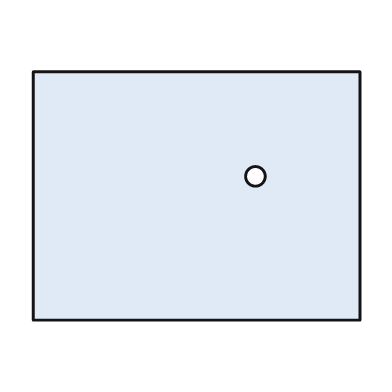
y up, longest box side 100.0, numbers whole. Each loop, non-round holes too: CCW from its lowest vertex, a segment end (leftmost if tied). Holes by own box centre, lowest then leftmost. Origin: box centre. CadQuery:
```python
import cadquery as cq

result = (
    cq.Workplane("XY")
    .moveTo(-50.0, -38.0)
    .lineTo(50.0, -38.0)
    .lineTo(50.0, 38.0)
    .lineTo(-50.0, 38.0)
    .close()
    .moveTo(18.0, 6.0)
    .circle(3.0)
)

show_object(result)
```